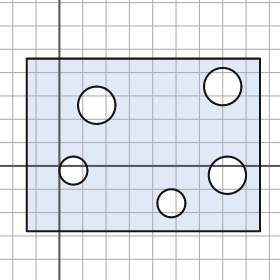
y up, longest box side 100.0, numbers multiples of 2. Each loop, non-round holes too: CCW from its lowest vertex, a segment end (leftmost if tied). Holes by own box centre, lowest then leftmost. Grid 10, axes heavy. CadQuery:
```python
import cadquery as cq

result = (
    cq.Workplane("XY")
    .moveTo(-14.0, -28.0)
    .lineTo(86.0, -28.0)
    .lineTo(86.0, 46.0)
    .lineTo(-14.0, 46.0)
    .close()
    .moveTo(48.0, -16.0)
    .circle(6.0)
    .moveTo(72.0, -4.0)
    .circle(8.0)
    .moveTo(6.0, -2.0)
    .circle(6.0)
    .moveTo(16.0, 26.0)
    .circle(8.0)
    .moveTo(70.0, 34.0)
    .circle(8.0)
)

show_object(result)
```